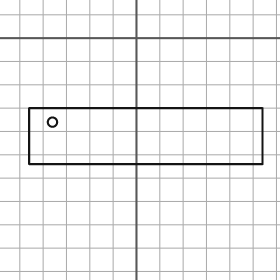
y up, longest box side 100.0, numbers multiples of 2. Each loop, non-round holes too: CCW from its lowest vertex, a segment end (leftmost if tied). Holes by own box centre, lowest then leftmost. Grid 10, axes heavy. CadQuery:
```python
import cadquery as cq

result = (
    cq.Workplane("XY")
    .moveTo(-46.0, -54.0)
    .lineTo(54.0, -54.0)
    .lineTo(54.0, -30.0)
    .lineTo(-46.0, -30.0)
    .close()
    .moveTo(-36.0, -36.0)
    .circle(2.0)
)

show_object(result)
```